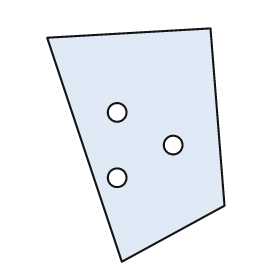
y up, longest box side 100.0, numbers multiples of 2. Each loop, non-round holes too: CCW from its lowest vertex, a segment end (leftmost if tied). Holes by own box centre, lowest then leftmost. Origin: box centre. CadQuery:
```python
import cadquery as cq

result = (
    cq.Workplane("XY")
    .moveTo(-6.0, -50.0)
    .lineTo(38.0, -26.0)
    .lineTo(32.0, 50.0)
    .lineTo(-38.0, 46.0)
    .close()
    .moveTo(-8.0, -14.0)
    .circle(4.0)
    .moveTo(16.0, 0.0)
    .circle(4.0)
    .moveTo(-8.0, 14.0)
    .circle(4.0)
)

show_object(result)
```